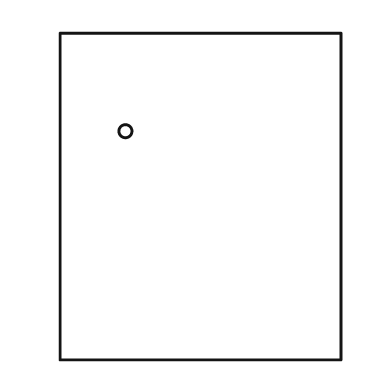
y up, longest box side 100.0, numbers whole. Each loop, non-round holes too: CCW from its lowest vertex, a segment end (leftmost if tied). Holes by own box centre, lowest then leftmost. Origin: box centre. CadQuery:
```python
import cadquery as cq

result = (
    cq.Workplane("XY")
    .moveTo(-43.0, -50.0)
    .lineTo(43.0, -50.0)
    .lineTo(43.0, 50.0)
    .lineTo(-43.0, 50.0)
    .close()
    .moveTo(-23.0, 20.0)
    .circle(2.0)
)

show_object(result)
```